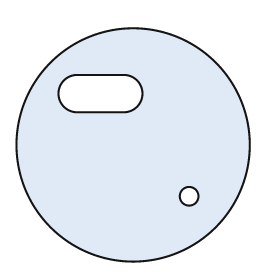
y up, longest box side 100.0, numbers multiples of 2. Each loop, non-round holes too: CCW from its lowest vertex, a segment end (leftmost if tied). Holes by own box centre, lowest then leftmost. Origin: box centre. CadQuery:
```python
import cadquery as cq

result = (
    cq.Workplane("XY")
    .moveTo(0.0, 0.0)
    .circle(50.0)
    .moveTo(24.0, -22.0)
    .circle(4.0)
    .moveTo(-24.0, 14.0)
    .lineTo(-4.0, 14.0)
    .threePointArc((4.0, 22.0), (-4.0, 30.0))
    .lineTo(-24.0, 30.0)
    .threePointArc((-32.0, 22.0), (-24.0, 14.0))
    .close()
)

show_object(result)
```